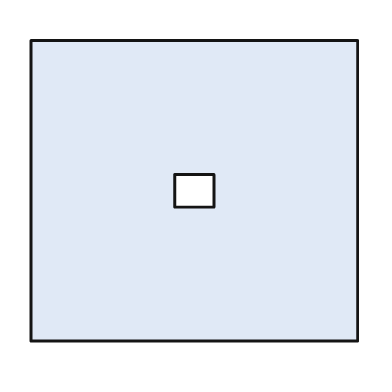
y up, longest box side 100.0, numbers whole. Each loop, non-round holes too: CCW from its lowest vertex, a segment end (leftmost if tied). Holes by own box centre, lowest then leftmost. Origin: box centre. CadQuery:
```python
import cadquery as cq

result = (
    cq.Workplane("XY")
    .moveTo(-50.0, -46.0)
    .lineTo(50.0, -46.0)
    .lineTo(50.0, 46.0)
    .lineTo(-50.0, 46.0)
    .close()
    .moveTo(-6.0, -5.0)
    .lineTo(6.0, -5.0)
    .lineTo(6.0, 5.0)
    .lineTo(-6.0, 5.0)
    .close()
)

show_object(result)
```